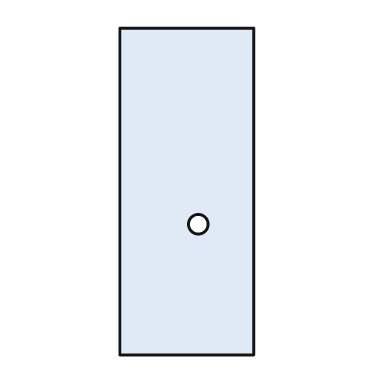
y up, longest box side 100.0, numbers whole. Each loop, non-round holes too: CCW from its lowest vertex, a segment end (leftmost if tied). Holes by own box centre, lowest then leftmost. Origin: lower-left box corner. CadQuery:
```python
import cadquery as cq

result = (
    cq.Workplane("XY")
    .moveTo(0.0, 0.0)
    .lineTo(41.0, 0.0)
    .lineTo(41.0, 100.0)
    .lineTo(0.0, 100.0)
    .close()
    .moveTo(24.0, 40.0)
    .circle(3.0)
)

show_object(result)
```